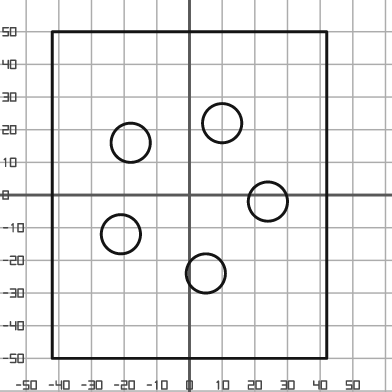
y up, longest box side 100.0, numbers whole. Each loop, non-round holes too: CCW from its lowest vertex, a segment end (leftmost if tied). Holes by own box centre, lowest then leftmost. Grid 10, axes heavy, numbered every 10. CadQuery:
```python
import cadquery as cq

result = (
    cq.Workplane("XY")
    .moveTo(-42.0, -50.0)
    .lineTo(42.0, -50.0)
    .lineTo(42.0, 50.0)
    .lineTo(-42.0, 50.0)
    .close()
    .moveTo(5.0, -24.0)
    .circle(6.0)
    .moveTo(-21.0, -12.0)
    .circle(6.0)
    .moveTo(24.0, -2.0)
    .circle(6.0)
    .moveTo(-18.0, 16.0)
    .circle(6.0)
    .moveTo(10.0, 22.0)
    .circle(6.0)
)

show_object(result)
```